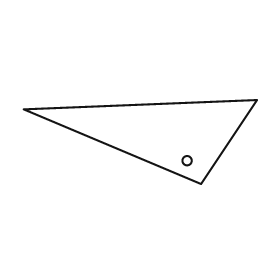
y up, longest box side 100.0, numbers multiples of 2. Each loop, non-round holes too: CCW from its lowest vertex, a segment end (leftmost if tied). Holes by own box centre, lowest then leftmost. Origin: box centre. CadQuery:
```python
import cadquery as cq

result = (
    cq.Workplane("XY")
    .moveTo(26.0, -18.0)
    .lineTo(50.0, 18.0)
    .lineTo(-50.0, 14.0)
    .close()
    .moveTo(20.0, -8.0)
    .circle(2.0)
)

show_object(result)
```